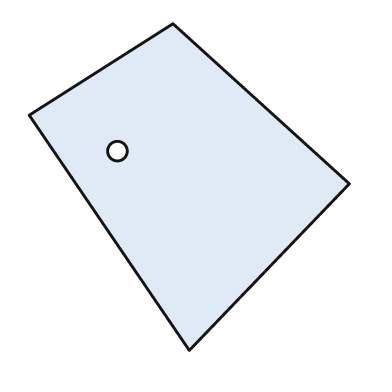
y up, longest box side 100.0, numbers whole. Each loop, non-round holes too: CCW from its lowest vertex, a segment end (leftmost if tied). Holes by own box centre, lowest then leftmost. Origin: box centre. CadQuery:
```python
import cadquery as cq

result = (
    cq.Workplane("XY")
    .moveTo(0.0, -50.0)
    .lineTo(49.0, 1.0)
    .lineTo(-5.0, 50.0)
    .lineTo(-49.0, 22.0)
    .close()
    .moveTo(-22.0, 11.0)
    .circle(3.0)
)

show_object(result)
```